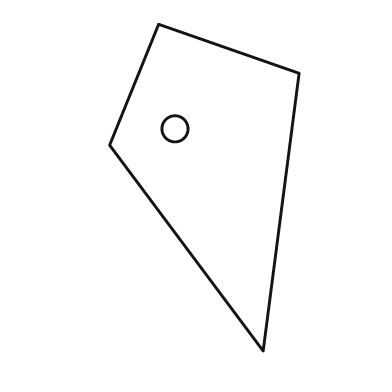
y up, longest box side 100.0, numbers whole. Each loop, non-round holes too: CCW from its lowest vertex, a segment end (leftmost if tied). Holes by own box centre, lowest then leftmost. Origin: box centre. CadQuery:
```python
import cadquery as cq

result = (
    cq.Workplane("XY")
    .moveTo(18.0, -50.0)
    .lineTo(29.0, 35.0)
    .lineTo(-14.0, 50.0)
    .lineTo(-29.0, 13.0)
    .close()
    .moveTo(-9.0, 18.0)
    .circle(4.0)
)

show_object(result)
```